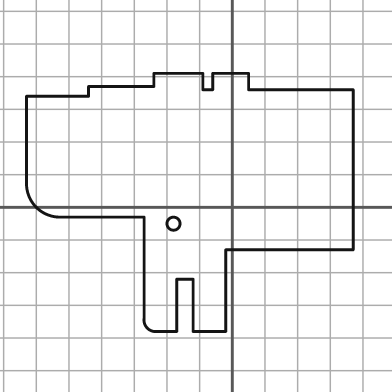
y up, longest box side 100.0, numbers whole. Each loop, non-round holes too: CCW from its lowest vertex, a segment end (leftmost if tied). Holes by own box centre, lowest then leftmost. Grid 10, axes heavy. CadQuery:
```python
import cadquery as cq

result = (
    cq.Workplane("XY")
    .moveTo(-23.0, -38.0)
    .lineTo(-17.0, -38.0)
    .lineTo(-17.0, -22.0)
    .lineTo(-12.0, -22.0)
    .lineTo(-12.0, -38.0)
    .lineTo(-2.0, -38.0)
    .lineTo(-2.0, -13.0)
    .lineTo(37.0, -13.0)
    .lineTo(37.0, 36.0)
    .lineTo(5.0, 36.0)
    .lineTo(5.0, 41.0)
    .lineTo(-6.0, 41.0)
    .lineTo(-6.0, 36.0)
    .lineTo(-9.0, 36.0)
    .lineTo(-9.0, 41.0)
    .lineTo(-24.0, 41.0)
    .lineTo(-24.0, 37.0)
    .lineTo(-44.0, 37.0)
    .lineTo(-44.0, 34.0)
    .lineTo(-63.0, 34.0)
    .lineTo(-63.0, 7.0)
    .threePointArc((-60.0, 0.0), (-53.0, -3.0))
    .lineTo(-27.0, -3.0)
    .lineTo(-27.0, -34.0)
    .threePointArc((-26.0, -37.0), (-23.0, -38.0))
    .close()
    .moveTo(-18.0, -5.0)
    .circle(2.0)
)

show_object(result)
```